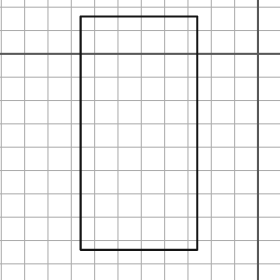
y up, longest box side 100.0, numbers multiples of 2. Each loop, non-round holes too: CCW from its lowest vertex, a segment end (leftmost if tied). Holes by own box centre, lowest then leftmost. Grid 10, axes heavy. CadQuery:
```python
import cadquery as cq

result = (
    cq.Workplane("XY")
    .moveTo(-76.0, -84.0)
    .lineTo(-26.0, -84.0)
    .lineTo(-26.0, 16.0)
    .lineTo(-76.0, 16.0)
    .close()
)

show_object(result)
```